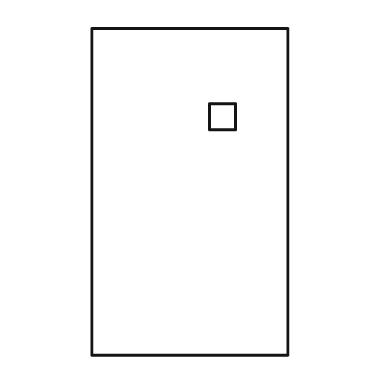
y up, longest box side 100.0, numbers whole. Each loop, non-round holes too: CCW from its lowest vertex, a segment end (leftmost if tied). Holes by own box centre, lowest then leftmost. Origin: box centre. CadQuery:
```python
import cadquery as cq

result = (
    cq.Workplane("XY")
    .moveTo(-30.0, -50.0)
    .lineTo(30.0, -50.0)
    .lineTo(30.0, 50.0)
    .lineTo(-30.0, 50.0)
    .close()
    .moveTo(6.0, 19.0)
    .lineTo(14.0, 19.0)
    .lineTo(14.0, 27.0)
    .lineTo(6.0, 27.0)
    .close()
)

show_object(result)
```